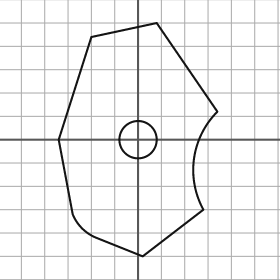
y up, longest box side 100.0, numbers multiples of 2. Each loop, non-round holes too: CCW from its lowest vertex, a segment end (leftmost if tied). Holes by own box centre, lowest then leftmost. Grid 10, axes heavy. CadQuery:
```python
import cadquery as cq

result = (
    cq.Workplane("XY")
    .moveTo(2.0, -50.0)
    .lineTo(28.0, -30.0)
    .threePointArc((24.0, -8.0), (34.0, 12.0))
    .lineTo(8.0, 50.0)
    .lineTo(-20.0, 44.0)
    .lineTo(-34.0, 0.0)
    .lineTo(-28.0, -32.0)
    .threePointArc((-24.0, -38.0), (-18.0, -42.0))
    .close()
    .moveTo(0.0, 0.0)
    .circle(8.0)
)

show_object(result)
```